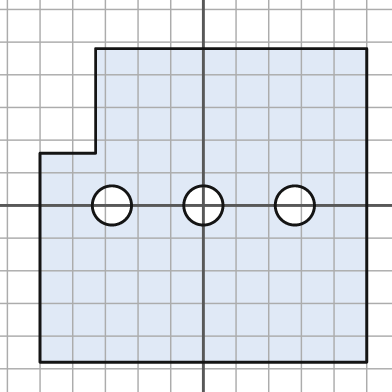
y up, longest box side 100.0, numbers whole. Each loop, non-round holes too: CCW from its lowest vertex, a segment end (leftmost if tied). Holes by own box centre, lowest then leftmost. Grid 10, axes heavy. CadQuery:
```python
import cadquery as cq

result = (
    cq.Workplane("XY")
    .moveTo(-50.0, -48.0)
    .lineTo(50.0, -48.0)
    .lineTo(50.0, 48.0)
    .lineTo(-33.0, 48.0)
    .lineTo(-33.0, 16.0)
    .lineTo(-50.0, 16.0)
    .close()
    .moveTo(-28.0, 0.0)
    .circle(6.0)
    .moveTo(0.0, 0.0)
    .circle(6.0)
    .moveTo(28.0, 0.0)
    .circle(6.0)
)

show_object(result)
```